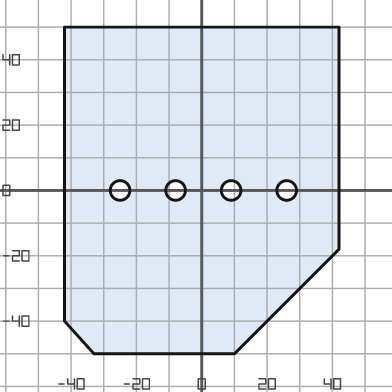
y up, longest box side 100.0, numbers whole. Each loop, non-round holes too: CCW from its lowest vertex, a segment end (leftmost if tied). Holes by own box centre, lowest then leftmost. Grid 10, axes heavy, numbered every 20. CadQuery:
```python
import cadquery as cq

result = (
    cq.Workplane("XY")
    .moveTo(-33.0, -50.0)
    .lineTo(10.0, -50.0)
    .lineTo(42.0, -18.0)
    .lineTo(42.0, 50.0)
    .lineTo(-42.0, 50.0)
    .lineTo(-42.0, -40.0)
    .close()
    .moveTo(-25.0, 0.0)
    .circle(3.0)
    .moveTo(-8.0, 0.0)
    .circle(3.0)
    .moveTo(9.0, 0.0)
    .circle(3.0)
    .moveTo(26.0, 0.0)
    .circle(3.0)
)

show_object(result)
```